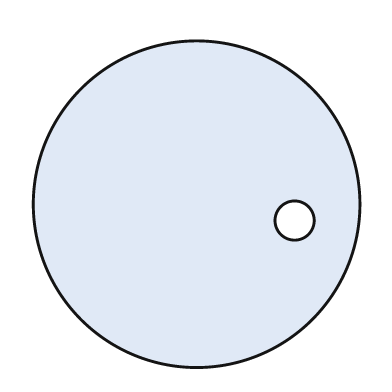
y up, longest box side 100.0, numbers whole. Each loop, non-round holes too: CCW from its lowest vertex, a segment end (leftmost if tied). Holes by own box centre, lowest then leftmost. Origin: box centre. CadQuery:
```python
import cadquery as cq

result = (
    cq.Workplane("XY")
    .moveTo(0.0, 0.0)
    .circle(50.0)
    .moveTo(30.0, -5.0)
    .circle(6.0)
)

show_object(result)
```